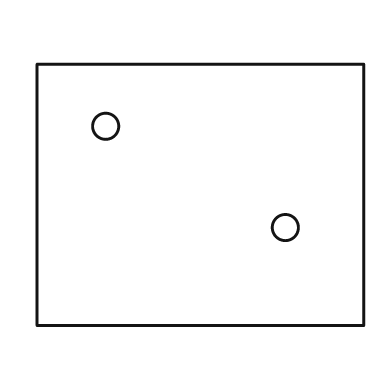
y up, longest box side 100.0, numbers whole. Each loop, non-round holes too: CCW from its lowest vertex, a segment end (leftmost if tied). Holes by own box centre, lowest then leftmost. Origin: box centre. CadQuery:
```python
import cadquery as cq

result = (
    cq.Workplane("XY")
    .moveTo(-50.0, -40.0)
    .lineTo(50.0, -40.0)
    .lineTo(50.0, 40.0)
    .lineTo(-50.0, 40.0)
    .close()
    .moveTo(26.0, -10.0)
    .circle(4.0)
    .moveTo(-29.0, 21.0)
    .circle(4.0)
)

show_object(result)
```